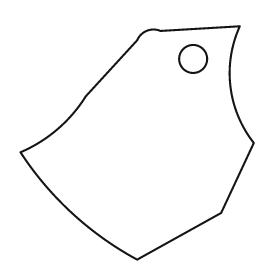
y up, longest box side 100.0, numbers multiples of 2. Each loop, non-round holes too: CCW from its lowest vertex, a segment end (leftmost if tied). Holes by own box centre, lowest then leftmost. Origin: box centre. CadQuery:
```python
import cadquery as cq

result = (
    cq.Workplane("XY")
    .moveTo(0.0, -50.0)
    .lineTo(36.0, -30.0)
    .lineTo(50.0, 0.0)
    .threePointArc((40.0, 24.0), (44.0, 50.0))
    .lineTo(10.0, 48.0)
    .threePointArc((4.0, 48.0), (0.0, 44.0))
    .lineTo(-22.0, 20.0)
    .threePointArc((-34.0, 6.0), (-50.0, -4.0))
    .threePointArc((-28.0, -30.0), (0.0, -50.0))
    .close()
    .moveTo(24.0, 36.0)
    .circle(6.0)
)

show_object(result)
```